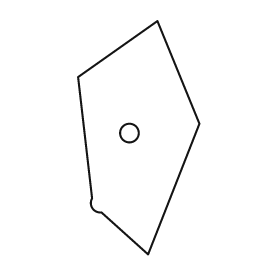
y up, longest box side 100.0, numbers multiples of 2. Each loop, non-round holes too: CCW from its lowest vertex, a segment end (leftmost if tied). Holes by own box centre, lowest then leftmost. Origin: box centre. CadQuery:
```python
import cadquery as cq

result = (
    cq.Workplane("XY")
    .moveTo(4.0, -50.0)
    .lineTo(26.0, 6.0)
    .lineTo(8.0, 50.0)
    .lineTo(-26.0, 26.0)
    .lineTo(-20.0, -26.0)
    .threePointArc((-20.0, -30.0), (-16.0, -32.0))
    .close()
    .moveTo(-4.0, 2.0)
    .circle(4.0)
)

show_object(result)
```